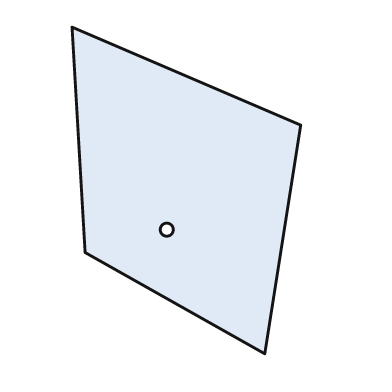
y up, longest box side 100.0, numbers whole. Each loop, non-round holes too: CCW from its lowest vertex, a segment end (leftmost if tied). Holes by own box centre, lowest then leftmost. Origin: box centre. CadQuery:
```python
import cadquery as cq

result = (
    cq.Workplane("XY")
    .moveTo(24.0, -50.0)
    .lineTo(35.0, 20.0)
    .lineTo(-35.0, 50.0)
    .lineTo(-31.0, -19.0)
    .close()
    .moveTo(-6.0, -12.0)
    .circle(2.0)
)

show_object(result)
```